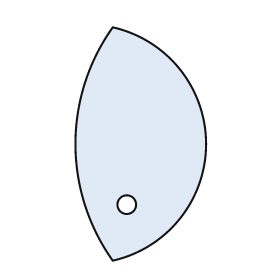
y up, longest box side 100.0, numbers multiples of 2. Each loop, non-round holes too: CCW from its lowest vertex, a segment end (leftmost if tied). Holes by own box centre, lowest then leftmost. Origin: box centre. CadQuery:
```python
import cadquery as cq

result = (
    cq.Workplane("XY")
    .moveTo(-12.0, -50.0)
    .threePointArc((28.0, 0.0), (-12.0, 50.0))
    .threePointArc((-28.0, 0.0), (-12.0, -50.0))
    .close()
    .moveTo(-6.0, -26.0)
    .circle(4.0)
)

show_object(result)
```